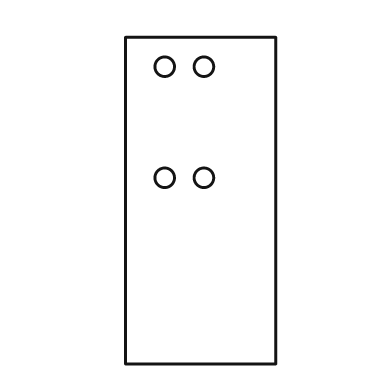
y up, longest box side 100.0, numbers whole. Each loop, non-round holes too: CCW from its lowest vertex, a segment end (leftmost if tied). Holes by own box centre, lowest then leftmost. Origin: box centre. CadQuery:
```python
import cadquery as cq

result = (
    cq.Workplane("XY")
    .moveTo(-23.0, -50.0)
    .lineTo(23.0, -50.0)
    .lineTo(23.0, 50.0)
    .lineTo(-23.0, 50.0)
    .close()
    .moveTo(-11.0, 7.0)
    .circle(3.0)
    .moveTo(1.0, 7.0)
    .circle(3.0)
    .moveTo(-11.0, 41.0)
    .circle(3.0)
    .moveTo(1.0, 41.0)
    .circle(3.0)
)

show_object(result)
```